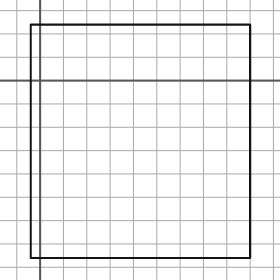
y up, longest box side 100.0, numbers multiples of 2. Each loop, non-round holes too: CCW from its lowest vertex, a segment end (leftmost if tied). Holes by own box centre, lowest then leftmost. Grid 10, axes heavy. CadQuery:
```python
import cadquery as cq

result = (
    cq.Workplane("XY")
    .moveTo(-4.0, -76.0)
    .lineTo(90.0, -76.0)
    .lineTo(90.0, 24.0)
    .lineTo(-4.0, 24.0)
    .close()
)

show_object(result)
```